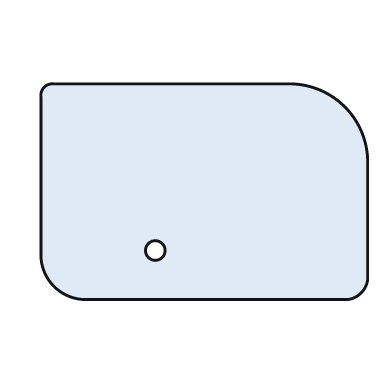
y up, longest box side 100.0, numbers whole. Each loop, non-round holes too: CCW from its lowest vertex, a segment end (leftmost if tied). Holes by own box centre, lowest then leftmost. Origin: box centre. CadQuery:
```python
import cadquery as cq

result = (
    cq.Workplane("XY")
    .moveTo(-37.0, -33.0)
    .lineTo(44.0, -33.0)
    .threePointArc((48.0, -31.0), (50.0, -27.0))
    .lineTo(50.0, 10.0)
    .threePointArc((43.0, 26.0), (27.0, 33.0))
    .lineTo(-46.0, 33.0)
    .threePointArc((-49.0, 32.0), (-50.0, 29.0))
    .lineTo(-50.0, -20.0)
    .threePointArc((-46.0, -29.0), (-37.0, -33.0))
    .close()
    .moveTo(-15.0, -18.0)
    .circle(3.0)
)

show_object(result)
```